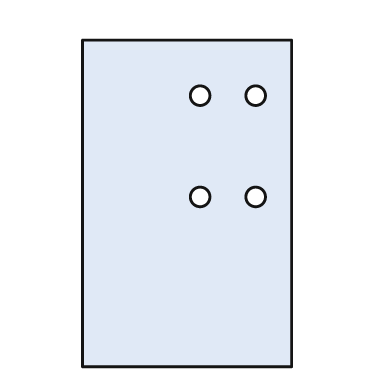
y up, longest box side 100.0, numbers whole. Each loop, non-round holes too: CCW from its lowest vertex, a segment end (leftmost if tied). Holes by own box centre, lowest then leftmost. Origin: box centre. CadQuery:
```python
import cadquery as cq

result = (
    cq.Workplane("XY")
    .moveTo(-32.0, -50.0)
    .lineTo(32.0, -50.0)
    .lineTo(32.0, 50.0)
    .lineTo(-32.0, 50.0)
    .close()
    .moveTo(4.0, 2.0)
    .circle(3.0)
    .moveTo(21.0, 2.0)
    .circle(3.0)
    .moveTo(4.0, 33.0)
    .circle(3.0)
    .moveTo(21.0, 33.0)
    .circle(3.0)
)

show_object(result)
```